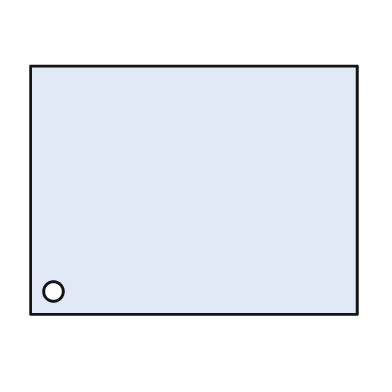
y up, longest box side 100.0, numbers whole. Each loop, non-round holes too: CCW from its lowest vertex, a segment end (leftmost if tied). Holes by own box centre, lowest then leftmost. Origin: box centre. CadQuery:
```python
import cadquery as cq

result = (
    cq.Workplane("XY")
    .moveTo(-50.0, -38.0)
    .lineTo(50.0, -38.0)
    .lineTo(50.0, 38.0)
    .lineTo(-50.0, 38.0)
    .close()
    .moveTo(-43.0, -31.0)
    .circle(3.0)
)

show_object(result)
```